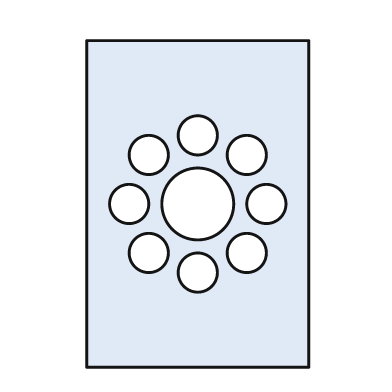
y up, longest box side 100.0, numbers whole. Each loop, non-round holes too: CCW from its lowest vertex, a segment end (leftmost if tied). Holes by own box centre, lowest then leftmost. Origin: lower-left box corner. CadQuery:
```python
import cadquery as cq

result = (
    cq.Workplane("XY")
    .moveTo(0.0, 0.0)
    .lineTo(68.0, 0.0)
    .lineTo(68.0, 100.0)
    .lineTo(0.0, 100.0)
    .close()
    .moveTo(34.0, 29.0)
    .circle(6.0)
    .moveTo(19.0, 35.0)
    .circle(6.0)
    .moveTo(49.0, 35.0)
    .circle(6.0)
    .moveTo(13.0, 50.0)
    .circle(6.0)
    .moveTo(34.0, 50.0)
    .circle(11.0)
    .moveTo(55.0, 50.0)
    .circle(6.0)
    .moveTo(19.0, 65.0)
    .circle(6.0)
    .moveTo(49.0, 65.0)
    .circle(6.0)
    .moveTo(34.0, 71.0)
    .circle(6.0)
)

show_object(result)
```